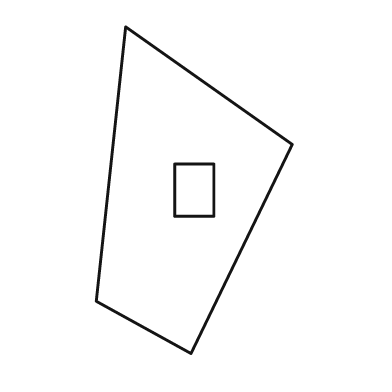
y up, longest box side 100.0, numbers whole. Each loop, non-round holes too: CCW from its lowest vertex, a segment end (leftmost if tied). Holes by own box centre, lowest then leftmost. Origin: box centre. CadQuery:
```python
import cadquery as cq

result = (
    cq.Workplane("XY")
    .moveTo(-1.0, -50.0)
    .lineTo(30.0, 14.0)
    .lineTo(-21.0, 50.0)
    .lineTo(-30.0, -34.0)
    .close()
    .moveTo(-6.0, -8.0)
    .lineTo(6.0, -8.0)
    .lineTo(6.0, 8.0)
    .lineTo(-6.0, 8.0)
    .close()
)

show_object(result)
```